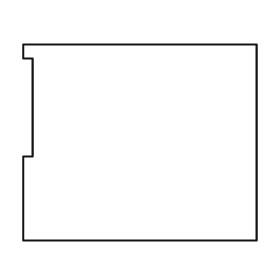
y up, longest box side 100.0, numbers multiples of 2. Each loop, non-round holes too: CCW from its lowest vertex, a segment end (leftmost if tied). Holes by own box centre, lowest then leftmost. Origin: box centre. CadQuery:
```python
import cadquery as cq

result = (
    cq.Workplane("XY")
    .moveTo(-50.0, -42.0)
    .lineTo(50.0, -42.0)
    .lineTo(50.0, 42.0)
    .lineTo(-50.0, 42.0)
    .lineTo(-50.0, 36.0)
    .lineTo(-46.0, 36.0)
    .lineTo(-46.0, -6.0)
    .lineTo(-50.0, -6.0)
    .close()
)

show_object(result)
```